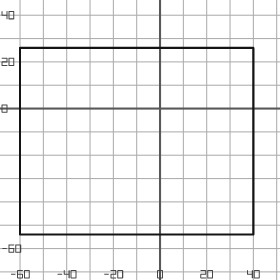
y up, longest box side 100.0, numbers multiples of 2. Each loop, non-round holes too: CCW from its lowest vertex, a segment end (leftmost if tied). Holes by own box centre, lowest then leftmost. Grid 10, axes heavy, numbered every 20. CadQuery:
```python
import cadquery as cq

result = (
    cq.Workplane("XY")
    .moveTo(-60.0, -54.0)
    .lineTo(40.0, -54.0)
    .lineTo(40.0, 26.0)
    .lineTo(-60.0, 26.0)
    .close()
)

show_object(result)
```